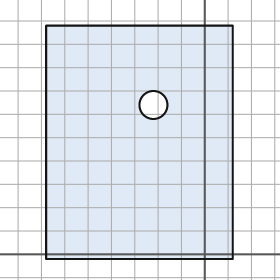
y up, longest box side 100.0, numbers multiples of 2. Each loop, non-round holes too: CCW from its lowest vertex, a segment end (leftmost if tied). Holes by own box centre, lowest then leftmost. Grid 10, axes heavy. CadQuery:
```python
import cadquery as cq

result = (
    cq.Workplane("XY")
    .moveTo(-68.0, -2.0)
    .lineTo(12.0, -2.0)
    .lineTo(12.0, 98.0)
    .lineTo(-68.0, 98.0)
    .close()
    .moveTo(-22.0, 64.0)
    .circle(6.0)
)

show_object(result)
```